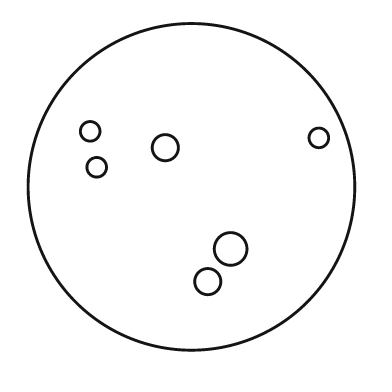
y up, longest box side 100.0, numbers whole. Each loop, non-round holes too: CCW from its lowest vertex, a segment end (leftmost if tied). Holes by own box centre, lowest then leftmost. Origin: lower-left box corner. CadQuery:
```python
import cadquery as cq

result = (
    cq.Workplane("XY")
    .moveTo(50.0, 50.0)
    .circle(50.0)
    .moveTo(55.0, 21.0)
    .circle(4.0)
    .moveTo(62.0, 31.0)
    .circle(5.0)
    .moveTo(21.0, 56.0)
    .circle(3.0)
    .moveTo(42.0, 62.0)
    .circle(4.0)
    .moveTo(89.0, 65.0)
    .circle(3.0)
    .moveTo(19.0, 67.0)
    .circle(3.0)
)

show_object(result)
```